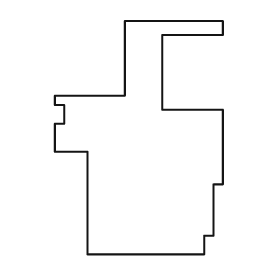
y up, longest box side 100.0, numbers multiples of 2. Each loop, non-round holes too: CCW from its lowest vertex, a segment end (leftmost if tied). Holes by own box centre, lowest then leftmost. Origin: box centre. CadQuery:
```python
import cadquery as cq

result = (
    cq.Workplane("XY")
    .moveTo(-22.0, -50.0)
    .lineTo(28.0, -50.0)
    .lineTo(28.0, -42.0)
    .lineTo(32.0, -42.0)
    .lineTo(32.0, -20.0)
    .lineTo(36.0, -20.0)
    .lineTo(36.0, 12.0)
    .lineTo(10.0, 12.0)
    .lineTo(10.0, 44.0)
    .lineTo(36.0, 44.0)
    .lineTo(36.0, 50.0)
    .lineTo(-6.0, 50.0)
    .lineTo(-6.0, 18.0)
    .lineTo(-36.0, 18.0)
    .lineTo(-36.0, 14.0)
    .lineTo(-32.0, 14.0)
    .lineTo(-32.0, 6.0)
    .lineTo(-36.0, 6.0)
    .lineTo(-36.0, -6.0)
    .lineTo(-22.0, -6.0)
    .close()
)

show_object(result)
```